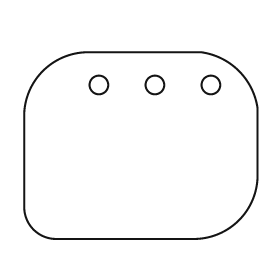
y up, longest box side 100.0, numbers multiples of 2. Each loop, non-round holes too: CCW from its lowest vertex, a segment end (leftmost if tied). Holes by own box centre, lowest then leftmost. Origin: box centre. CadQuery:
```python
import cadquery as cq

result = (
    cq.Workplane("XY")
    .moveTo(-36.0, -40.0)
    .lineTo(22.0, -40.0)
    .threePointArc((42.0, -32.0), (50.0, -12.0))
    .lineTo(50.0, 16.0)
    .threePointArc((42.0, 32.0), (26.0, 40.0))
    .lineTo(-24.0, 40.0)
    .threePointArc((-42.0, 32.0), (-50.0, 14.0))
    .lineTo(-50.0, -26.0)
    .threePointArc((-46.0, -36.0), (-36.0, -40.0))
    .close()
    .moveTo(-18.0, 26.0)
    .circle(4.0)
    .moveTo(6.0, 26.0)
    .circle(4.0)
    .moveTo(30.0, 26.0)
    .circle(4.0)
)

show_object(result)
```